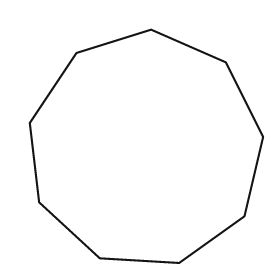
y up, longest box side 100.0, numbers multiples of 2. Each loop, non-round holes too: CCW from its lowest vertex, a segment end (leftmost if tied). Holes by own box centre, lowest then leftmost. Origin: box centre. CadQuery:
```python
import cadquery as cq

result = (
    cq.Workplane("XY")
    .moveTo(14.0, -50.0)
    .lineTo(42.0, -30.0)
    .lineTo(50.0, 4.0)
    .lineTo(34.0, 36.0)
    .lineTo(2.0, 50.0)
    .lineTo(-30.0, 40.0)
    .lineTo(-50.0, 10.0)
    .lineTo(-46.0, -24.0)
    .lineTo(-20.0, -48.0)
    .close()
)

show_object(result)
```